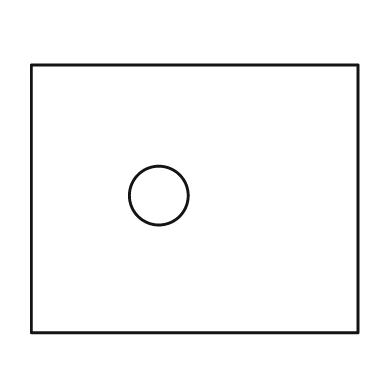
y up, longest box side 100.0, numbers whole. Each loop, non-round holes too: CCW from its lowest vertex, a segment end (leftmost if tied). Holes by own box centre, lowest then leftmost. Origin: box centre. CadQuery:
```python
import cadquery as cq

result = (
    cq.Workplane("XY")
    .moveTo(-50.0, -41.0)
    .lineTo(50.0, -41.0)
    .lineTo(50.0, 41.0)
    .lineTo(-50.0, 41.0)
    .close()
    .moveTo(-11.0, 1.0)
    .circle(9.0)
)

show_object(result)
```